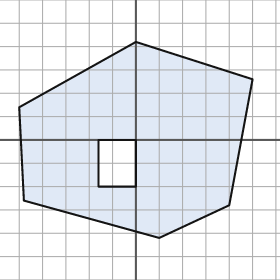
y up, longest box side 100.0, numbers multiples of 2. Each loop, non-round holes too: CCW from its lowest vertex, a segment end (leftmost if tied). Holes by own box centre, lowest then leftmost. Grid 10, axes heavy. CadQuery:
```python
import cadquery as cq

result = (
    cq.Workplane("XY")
    .moveTo(10.0, -42.0)
    .lineTo(40.0, -28.0)
    .lineTo(50.0, 26.0)
    .lineTo(0.0, 42.0)
    .lineTo(-50.0, 14.0)
    .lineTo(-48.0, -26.0)
    .close()
    .moveTo(-16.0, -20.0)
    .lineTo(0.0, -20.0)
    .lineTo(0.0, 0.0)
    .lineTo(-16.0, 0.0)
    .close()
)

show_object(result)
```